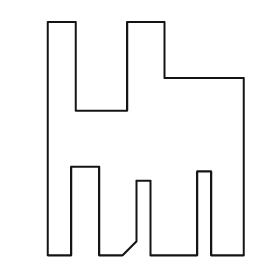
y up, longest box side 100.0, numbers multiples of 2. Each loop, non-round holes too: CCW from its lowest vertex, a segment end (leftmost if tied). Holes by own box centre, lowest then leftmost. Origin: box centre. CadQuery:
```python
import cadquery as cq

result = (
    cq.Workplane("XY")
    .moveTo(-42.0, -50.0)
    .lineTo(-32.0, -50.0)
    .lineTo(-32.0, -12.0)
    .lineTo(-20.0, -12.0)
    .lineTo(-20.0, -50.0)
    .lineTo(-10.0, -50.0)
    .lineTo(-4.0, -44.0)
    .lineTo(-4.0, -18.0)
    .lineTo(2.0, -18.0)
    .lineTo(2.0, -50.0)
    .lineTo(22.0, -50.0)
    .lineTo(22.0, -14.0)
    .lineTo(28.0, -14.0)
    .lineTo(28.0, -50.0)
    .lineTo(42.0, -50.0)
    .lineTo(42.0, 26.0)
    .lineTo(8.0, 26.0)
    .lineTo(8.0, 50.0)
    .lineTo(-8.0, 50.0)
    .lineTo(-8.0, 12.0)
    .lineTo(-30.0, 12.0)
    .lineTo(-30.0, 50.0)
    .lineTo(-42.0, 50.0)
    .close()
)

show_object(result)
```